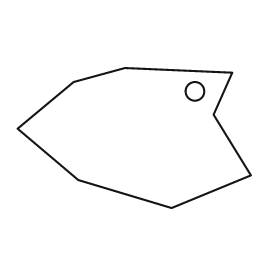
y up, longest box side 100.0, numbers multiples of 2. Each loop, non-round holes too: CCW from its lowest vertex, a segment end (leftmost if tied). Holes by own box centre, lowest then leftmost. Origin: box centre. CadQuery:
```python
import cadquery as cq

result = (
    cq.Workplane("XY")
    .moveTo(16.0, -30.0)
    .lineTo(50.0, -16.0)
    .lineTo(34.0, 10.0)
    .lineTo(42.0, 28.0)
    .lineTo(-4.0, 30.0)
    .lineTo(-26.0, 24.0)
    .lineTo(-50.0, 4.0)
    .lineTo(-24.0, -18.0)
    .close()
    .moveTo(26.0, 20.0)
    .circle(4.0)
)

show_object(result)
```